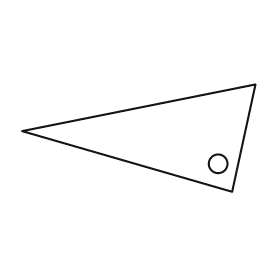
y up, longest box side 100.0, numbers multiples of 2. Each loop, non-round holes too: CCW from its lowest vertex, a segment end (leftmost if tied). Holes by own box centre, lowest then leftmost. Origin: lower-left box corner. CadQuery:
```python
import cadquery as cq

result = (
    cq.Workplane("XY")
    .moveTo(90.0, 0.0)
    .lineTo(100.0, 46.0)
    .lineTo(0.0, 26.0)
    .close()
    .moveTo(84.0, 12.0)
    .circle(4.0)
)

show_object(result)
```